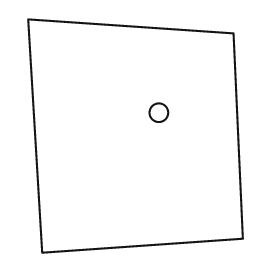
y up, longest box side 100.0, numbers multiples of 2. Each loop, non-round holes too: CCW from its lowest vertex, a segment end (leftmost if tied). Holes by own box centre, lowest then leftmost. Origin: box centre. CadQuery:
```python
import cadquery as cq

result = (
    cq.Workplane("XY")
    .moveTo(-40.0, -50.0)
    .lineTo(46.0, -44.0)
    .lineTo(42.0, 44.0)
    .lineTo(-46.0, 50.0)
    .close()
    .moveTo(10.0, 10.0)
    .circle(4.0)
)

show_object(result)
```